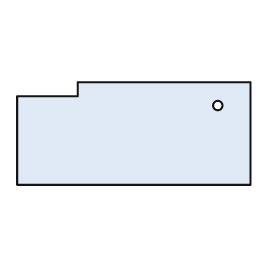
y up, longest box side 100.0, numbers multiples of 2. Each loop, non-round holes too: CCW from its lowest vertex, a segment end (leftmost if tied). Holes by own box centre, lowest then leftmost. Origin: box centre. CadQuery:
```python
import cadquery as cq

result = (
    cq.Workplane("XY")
    .moveTo(-50.0, -22.0)
    .lineTo(50.0, -22.0)
    .lineTo(50.0, 22.0)
    .lineTo(-24.0, 22.0)
    .lineTo(-24.0, 16.0)
    .lineTo(-50.0, 16.0)
    .close()
    .moveTo(36.0, 12.0)
    .circle(2.0)
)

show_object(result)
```